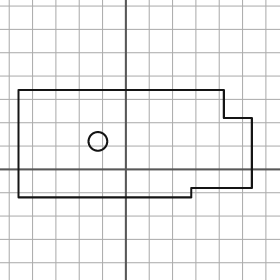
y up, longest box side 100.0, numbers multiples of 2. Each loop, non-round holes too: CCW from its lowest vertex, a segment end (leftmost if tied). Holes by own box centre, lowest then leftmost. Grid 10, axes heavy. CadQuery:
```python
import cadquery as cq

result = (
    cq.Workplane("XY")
    .moveTo(-46.0, -12.0)
    .lineTo(28.0, -12.0)
    .lineTo(28.0, -8.0)
    .lineTo(54.0, -8.0)
    .lineTo(54.0, 22.0)
    .lineTo(42.0, 22.0)
    .lineTo(42.0, 34.0)
    .lineTo(-46.0, 34.0)
    .close()
    .moveTo(-12.0, 12.0)
    .circle(4.0)
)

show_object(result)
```